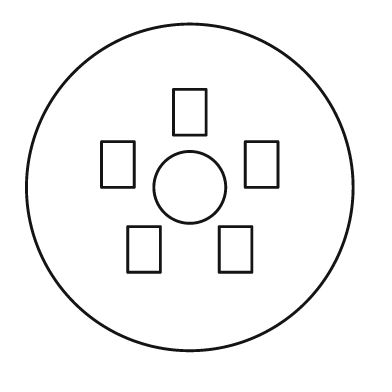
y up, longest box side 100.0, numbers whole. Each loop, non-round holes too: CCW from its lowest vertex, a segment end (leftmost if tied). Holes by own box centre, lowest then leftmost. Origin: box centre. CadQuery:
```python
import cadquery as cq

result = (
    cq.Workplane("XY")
    .moveTo(0.0, 0.0)
    .circle(50.0)
    .moveTo(-19.0, -26.0)
    .lineTo(-9.0, -26.0)
    .lineTo(-9.0, -12.0)
    .lineTo(-19.0, -12.0)
    .close()
    .moveTo(9.0, -26.0)
    .lineTo(19.0, -26.0)
    .lineTo(19.0, -12.0)
    .lineTo(9.0, -12.0)
    .close()
    .moveTo(0.0, 0.0)
    .circle(11.0)
    .moveTo(-27.0, 0.0)
    .lineTo(-17.0, 0.0)
    .lineTo(-17.0, 14.0)
    .lineTo(-27.0, 14.0)
    .close()
    .moveTo(17.0, 0.0)
    .lineTo(27.0, 0.0)
    .lineTo(27.0, 14.0)
    .lineTo(17.0, 14.0)
    .close()
    .moveTo(-5.0, 16.0)
    .lineTo(5.0, 16.0)
    .lineTo(5.0, 30.0)
    .lineTo(-5.0, 30.0)
    .close()
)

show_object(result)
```